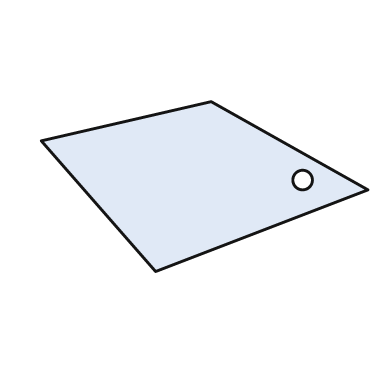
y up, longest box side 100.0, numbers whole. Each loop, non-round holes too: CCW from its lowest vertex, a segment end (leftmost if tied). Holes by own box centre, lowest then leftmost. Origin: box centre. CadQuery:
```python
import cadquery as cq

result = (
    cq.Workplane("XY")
    .moveTo(-15.0, -26.0)
    .lineTo(50.0, -1.0)
    .lineTo(2.0, 26.0)
    .lineTo(-50.0, 14.0)
    .close()
    .moveTo(30.0, 2.0)
    .circle(3.0)
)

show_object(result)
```